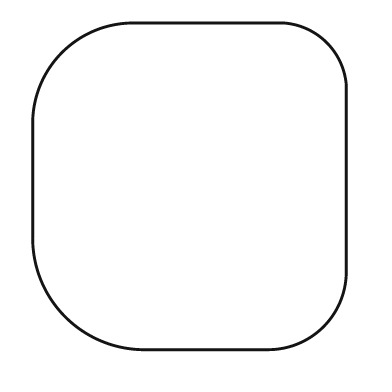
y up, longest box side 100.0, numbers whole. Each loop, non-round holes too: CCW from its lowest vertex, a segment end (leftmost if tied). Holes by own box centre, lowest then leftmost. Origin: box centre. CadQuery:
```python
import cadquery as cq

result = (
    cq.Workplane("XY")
    .moveTo(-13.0, -50.0)
    .lineTo(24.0, -50.0)
    .threePointArc((41.0, -43.0), (48.0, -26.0))
    .lineTo(48.0, 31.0)
    .threePointArc((42.0, 44.0), (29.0, 50.0))
    .lineTo(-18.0, 50.0)
    .threePointArc((-39.0, 41.0), (-48.0, 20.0))
    .lineTo(-48.0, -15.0)
    .threePointArc((-38.0, -40.0), (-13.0, -50.0))
    .close()
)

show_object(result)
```